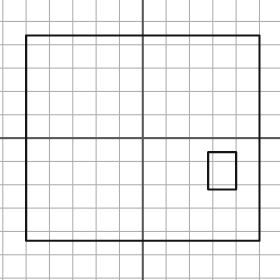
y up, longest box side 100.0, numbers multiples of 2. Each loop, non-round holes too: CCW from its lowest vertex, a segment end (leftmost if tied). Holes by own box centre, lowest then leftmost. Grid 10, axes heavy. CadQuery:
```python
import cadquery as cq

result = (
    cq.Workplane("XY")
    .moveTo(-50.0, -44.0)
    .lineTo(50.0, -44.0)
    .lineTo(50.0, 44.0)
    .lineTo(-50.0, 44.0)
    .close()
    .moveTo(28.0, -22.0)
    .lineTo(40.0, -22.0)
    .lineTo(40.0, -6.0)
    .lineTo(28.0, -6.0)
    .close()
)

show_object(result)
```